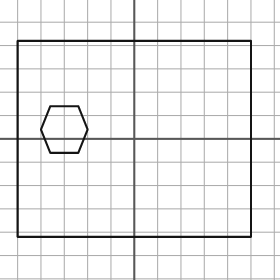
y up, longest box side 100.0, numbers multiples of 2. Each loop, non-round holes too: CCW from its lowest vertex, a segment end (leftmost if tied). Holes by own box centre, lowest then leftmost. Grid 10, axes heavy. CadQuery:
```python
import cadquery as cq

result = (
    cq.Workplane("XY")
    .moveTo(-50.0, -42.0)
    .lineTo(50.0, -42.0)
    .lineTo(50.0, 42.0)
    .lineTo(-50.0, 42.0)
    .close()
    .moveTo(-36.0, -6.0)
    .lineTo(-24.0, -6.0)
    .lineTo(-20.0, 4.0)
    .lineTo(-24.0, 14.0)
    .lineTo(-36.0, 14.0)
    .lineTo(-40.0, 4.0)
    .close()
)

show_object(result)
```